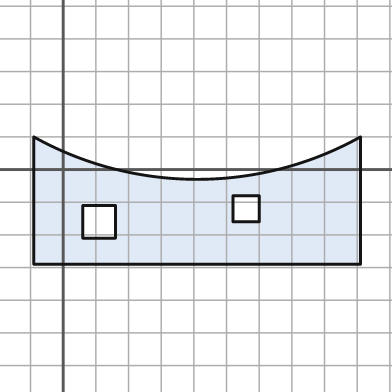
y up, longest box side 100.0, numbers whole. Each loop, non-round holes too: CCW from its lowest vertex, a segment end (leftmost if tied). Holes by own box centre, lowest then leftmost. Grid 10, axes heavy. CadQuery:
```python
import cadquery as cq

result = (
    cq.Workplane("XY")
    .moveTo(-9.0, -29.0)
    .lineTo(91.0, -29.0)
    .lineTo(91.0, 10.0)
    .threePointArc((41.0, -3.0), (-9.0, 10.0))
    .close()
    .moveTo(6.0, -21.0)
    .lineTo(16.0, -21.0)
    .lineTo(16.0, -11.0)
    .lineTo(6.0, -11.0)
    .close()
    .moveTo(52.0, -16.0)
    .lineTo(60.0, -16.0)
    .lineTo(60.0, -8.0)
    .lineTo(52.0, -8.0)
    .close()
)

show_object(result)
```